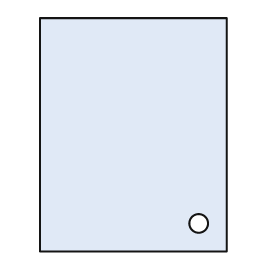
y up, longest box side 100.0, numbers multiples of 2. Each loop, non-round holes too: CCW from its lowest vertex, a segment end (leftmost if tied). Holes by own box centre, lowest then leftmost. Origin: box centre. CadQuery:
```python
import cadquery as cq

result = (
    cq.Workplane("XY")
    .moveTo(-40.0, -50.0)
    .lineTo(40.0, -50.0)
    .lineTo(40.0, 50.0)
    .lineTo(-40.0, 50.0)
    .close()
    .moveTo(28.0, -38.0)
    .circle(4.0)
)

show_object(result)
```